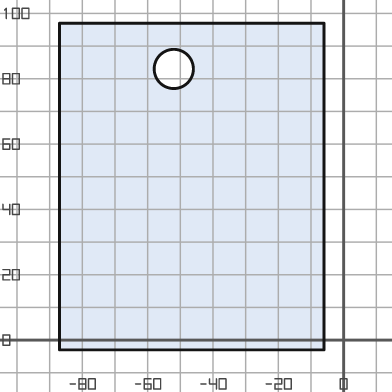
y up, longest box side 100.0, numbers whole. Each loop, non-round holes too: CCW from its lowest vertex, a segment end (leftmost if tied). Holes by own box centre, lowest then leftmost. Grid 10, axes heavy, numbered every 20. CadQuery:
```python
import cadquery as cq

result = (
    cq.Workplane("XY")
    .moveTo(-87.0, -3.0)
    .lineTo(-6.0, -3.0)
    .lineTo(-6.0, 97.0)
    .lineTo(-87.0, 97.0)
    .close()
    .moveTo(-52.0, 83.0)
    .circle(6.0)
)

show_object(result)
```